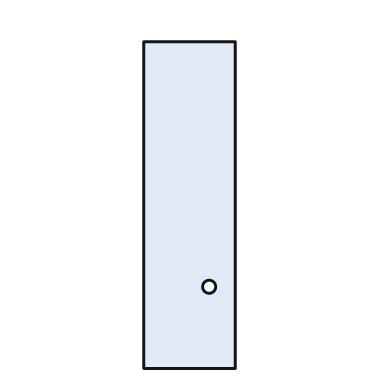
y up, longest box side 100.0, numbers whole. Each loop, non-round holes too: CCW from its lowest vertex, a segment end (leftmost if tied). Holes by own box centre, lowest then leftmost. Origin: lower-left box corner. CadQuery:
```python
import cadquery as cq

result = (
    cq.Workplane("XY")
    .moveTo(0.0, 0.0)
    .lineTo(28.0, 0.0)
    .lineTo(28.0, 100.0)
    .lineTo(0.0, 100.0)
    .close()
    .moveTo(20.0, 25.0)
    .circle(2.0)
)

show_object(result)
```